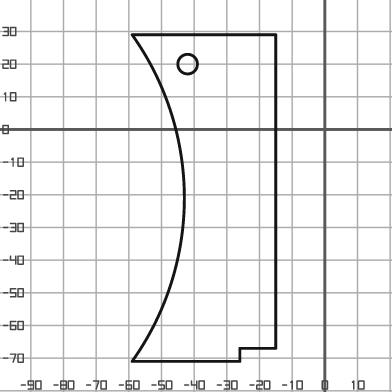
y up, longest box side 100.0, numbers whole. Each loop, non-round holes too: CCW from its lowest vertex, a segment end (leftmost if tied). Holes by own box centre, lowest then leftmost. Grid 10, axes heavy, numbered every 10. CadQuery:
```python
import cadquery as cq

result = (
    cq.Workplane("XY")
    .moveTo(-59.0, -71.0)
    .lineTo(-26.0, -71.0)
    .lineTo(-26.0, -67.0)
    .lineTo(-15.0, -67.0)
    .lineTo(-15.0, 29.0)
    .lineTo(-59.0, 29.0)
    .threePointArc((-43.0, -21.0), (-59.0, -71.0))
    .close()
    .moveTo(-42.0, 20.0)
    .circle(3.0)
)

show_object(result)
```